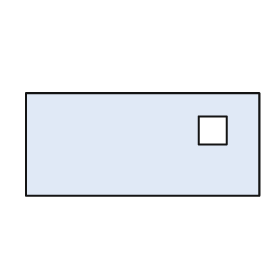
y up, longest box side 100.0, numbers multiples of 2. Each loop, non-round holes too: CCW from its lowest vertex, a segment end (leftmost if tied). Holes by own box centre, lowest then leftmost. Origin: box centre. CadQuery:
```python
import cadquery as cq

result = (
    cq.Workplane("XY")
    .moveTo(-50.0, -22.0)
    .lineTo(50.0, -22.0)
    .lineTo(50.0, 22.0)
    .lineTo(-50.0, 22.0)
    .close()
    .moveTo(24.0, 0.0)
    .lineTo(36.0, 0.0)
    .lineTo(36.0, 12.0)
    .lineTo(24.0, 12.0)
    .close()
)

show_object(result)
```